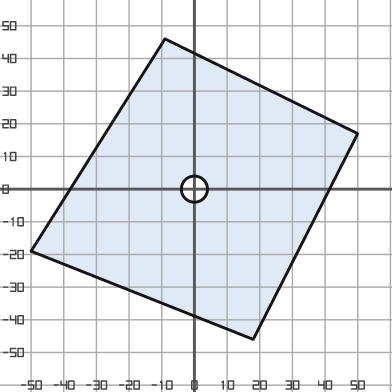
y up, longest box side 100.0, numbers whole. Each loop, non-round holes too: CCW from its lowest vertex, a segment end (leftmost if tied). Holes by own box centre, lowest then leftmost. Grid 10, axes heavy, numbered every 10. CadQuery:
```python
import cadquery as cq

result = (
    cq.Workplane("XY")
    .moveTo(18.0, -46.0)
    .lineTo(50.0, 17.0)
    .lineTo(-9.0, 46.0)
    .lineTo(-50.0, -19.0)
    .close()
    .moveTo(0.0, 0.0)
    .circle(4.0)
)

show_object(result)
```